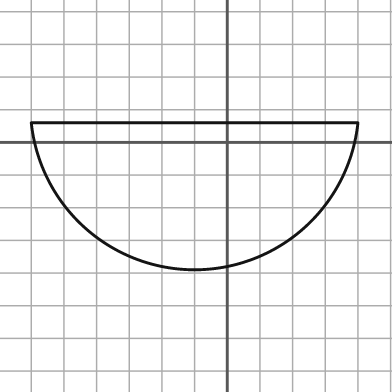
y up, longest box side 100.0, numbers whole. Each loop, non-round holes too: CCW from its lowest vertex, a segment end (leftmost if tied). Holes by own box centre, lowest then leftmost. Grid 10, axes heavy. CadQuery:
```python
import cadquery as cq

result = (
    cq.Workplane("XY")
    .moveTo(-60.0, 6.0)
    .threePointArc((-10.0, -39.0), (40.0, 6.0))
    .close()
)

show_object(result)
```